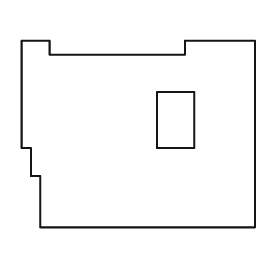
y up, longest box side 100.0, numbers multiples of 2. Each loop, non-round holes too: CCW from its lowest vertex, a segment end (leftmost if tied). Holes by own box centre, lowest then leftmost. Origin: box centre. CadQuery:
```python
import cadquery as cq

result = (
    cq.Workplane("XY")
    .moveTo(-42.0, -40.0)
    .lineTo(50.0, -40.0)
    .lineTo(50.0, 40.0)
    .lineTo(20.0, 40.0)
    .lineTo(20.0, 34.0)
    .lineTo(-38.0, 34.0)
    .lineTo(-38.0, 40.0)
    .lineTo(-50.0, 40.0)
    .lineTo(-50.0, -6.0)
    .lineTo(-46.0, -6.0)
    .lineTo(-46.0, -18.0)
    .lineTo(-42.0, -18.0)
    .close()
    .moveTo(8.0, -6.0)
    .lineTo(24.0, -6.0)
    .lineTo(24.0, 18.0)
    .lineTo(8.0, 18.0)
    .close()
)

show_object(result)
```